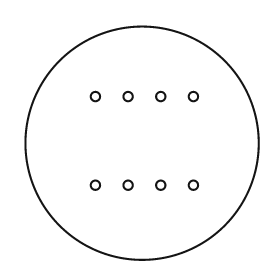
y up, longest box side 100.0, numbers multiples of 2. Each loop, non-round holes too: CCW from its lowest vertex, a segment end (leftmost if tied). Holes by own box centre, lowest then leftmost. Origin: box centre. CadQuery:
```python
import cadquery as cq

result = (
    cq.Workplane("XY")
    .moveTo(0.0, 0.0)
    .circle(50.0)
    .moveTo(-20.0, -18.0)
    .circle(2.0)
    .moveTo(-6.0, -18.0)
    .circle(2.0)
    .moveTo(8.0, -18.0)
    .circle(2.0)
    .moveTo(22.0, -18.0)
    .circle(2.0)
    .moveTo(-20.0, 20.0)
    .circle(2.0)
    .moveTo(-6.0, 20.0)
    .circle(2.0)
    .moveTo(8.0, 20.0)
    .circle(2.0)
    .moveTo(22.0, 20.0)
    .circle(2.0)
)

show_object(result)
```